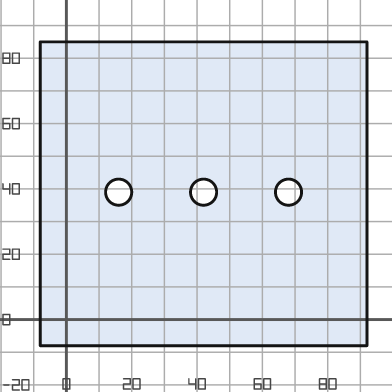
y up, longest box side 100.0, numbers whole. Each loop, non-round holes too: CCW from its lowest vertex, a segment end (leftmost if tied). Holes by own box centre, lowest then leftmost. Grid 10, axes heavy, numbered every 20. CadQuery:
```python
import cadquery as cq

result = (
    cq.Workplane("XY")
    .moveTo(-8.0, -8.0)
    .lineTo(92.0, -8.0)
    .lineTo(92.0, 85.0)
    .lineTo(-8.0, 85.0)
    .close()
    .moveTo(16.0, 39.0)
    .circle(4.0)
    .moveTo(42.0, 39.0)
    .circle(4.0)
    .moveTo(68.0, 39.0)
    .circle(4.0)
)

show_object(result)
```